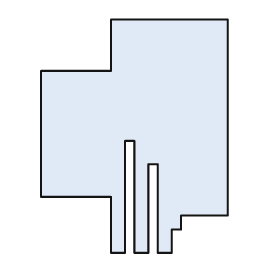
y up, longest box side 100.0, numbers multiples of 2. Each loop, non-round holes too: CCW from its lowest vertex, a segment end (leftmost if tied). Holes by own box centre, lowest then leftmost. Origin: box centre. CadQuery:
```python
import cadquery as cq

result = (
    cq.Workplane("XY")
    .moveTo(-10.0, -50.0)
    .lineTo(-4.0, -50.0)
    .lineTo(-4.0, -2.0)
    .lineTo(0.0, -2.0)
    .lineTo(0.0, -50.0)
    .lineTo(6.0, -50.0)
    .lineTo(6.0, -12.0)
    .lineTo(10.0, -12.0)
    .lineTo(10.0, -50.0)
    .lineTo(16.0, -50.0)
    .lineTo(16.0, -40.0)
    .lineTo(20.0, -40.0)
    .lineTo(20.0, -34.0)
    .lineTo(40.0, -34.0)
    .lineTo(40.0, 50.0)
    .lineTo(-10.0, 50.0)
    .lineTo(-10.0, 28.0)
    .lineTo(-40.0, 28.0)
    .lineTo(-40.0, -26.0)
    .lineTo(-10.0, -26.0)
    .close()
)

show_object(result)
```